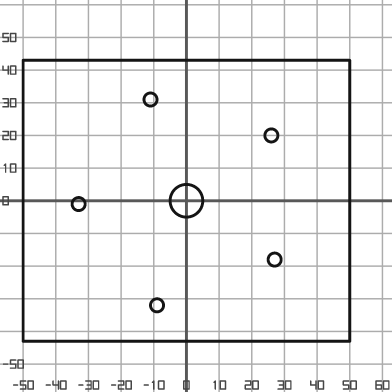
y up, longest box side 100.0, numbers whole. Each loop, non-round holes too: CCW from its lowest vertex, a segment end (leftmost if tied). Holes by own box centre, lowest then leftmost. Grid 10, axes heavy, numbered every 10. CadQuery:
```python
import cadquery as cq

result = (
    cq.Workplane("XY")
    .moveTo(-50.0, -43.0)
    .lineTo(50.0, -43.0)
    .lineTo(50.0, 43.0)
    .lineTo(-50.0, 43.0)
    .close()
    .moveTo(-9.0, -32.0)
    .circle(2.0)
    .moveTo(27.0, -18.0)
    .circle(2.0)
    .moveTo(-33.0, -1.0)
    .circle(2.0)
    .moveTo(0.0, 0.0)
    .circle(5.0)
    .moveTo(26.0, 20.0)
    .circle(2.0)
    .moveTo(-11.0, 31.0)
    .circle(2.0)
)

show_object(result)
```